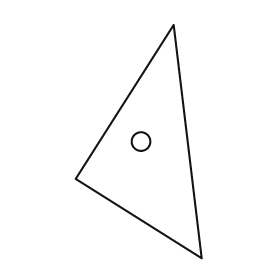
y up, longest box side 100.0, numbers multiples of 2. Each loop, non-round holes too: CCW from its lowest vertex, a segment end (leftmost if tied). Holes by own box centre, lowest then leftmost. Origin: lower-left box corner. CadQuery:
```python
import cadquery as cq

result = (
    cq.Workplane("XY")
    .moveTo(54.0, 0.0)
    .lineTo(42.0, 100.0)
    .lineTo(0.0, 34.0)
    .close()
    .moveTo(28.0, 50.0)
    .circle(4.0)
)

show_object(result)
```